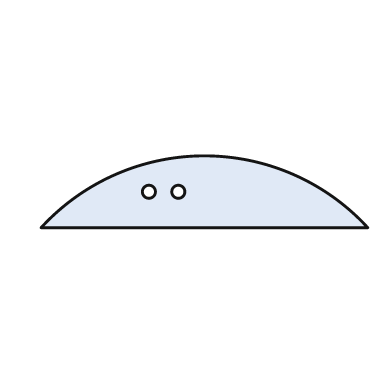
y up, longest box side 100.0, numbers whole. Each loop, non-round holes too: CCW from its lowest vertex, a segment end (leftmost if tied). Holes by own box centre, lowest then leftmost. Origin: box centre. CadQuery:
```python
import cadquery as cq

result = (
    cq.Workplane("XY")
    .moveTo(-50.0, -11.0)
    .lineTo(50.0, -11.0)
    .threePointArc((0.0, 11.0), (-50.0, -11.0))
    .close()
    .moveTo(-17.0, 0.0)
    .circle(2.0)
    .moveTo(-8.0, 0.0)
    .circle(2.0)
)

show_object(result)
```